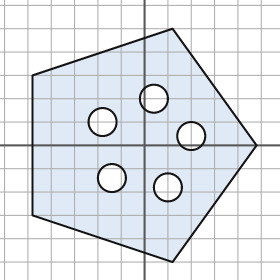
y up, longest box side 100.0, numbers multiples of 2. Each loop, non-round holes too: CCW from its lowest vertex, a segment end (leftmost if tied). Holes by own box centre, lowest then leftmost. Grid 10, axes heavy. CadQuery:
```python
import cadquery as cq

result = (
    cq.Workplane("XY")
    .moveTo(12.0, -50.0)
    .lineTo(48.0, 0.0)
    .lineTo(12.0, 50.0)
    .lineTo(-48.0, 30.0)
    .lineTo(-48.0, -30.0)
    .close()
    .moveTo(10.0, -18.0)
    .circle(6.0)
    .moveTo(-14.0, -14.0)
    .circle(6.0)
    .moveTo(20.0, 4.0)
    .circle(6.0)
    .moveTo(-18.0, 10.0)
    .circle(6.0)
    .moveTo(4.0, 20.0)
    .circle(6.0)
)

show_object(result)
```